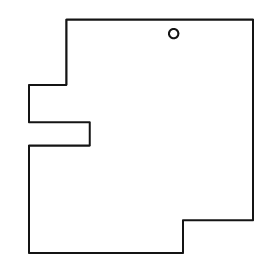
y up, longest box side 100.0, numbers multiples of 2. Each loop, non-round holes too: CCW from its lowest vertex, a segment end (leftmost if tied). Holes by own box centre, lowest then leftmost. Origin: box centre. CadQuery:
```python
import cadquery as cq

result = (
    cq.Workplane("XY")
    .moveTo(-48.0, -50.0)
    .lineTo(18.0, -50.0)
    .lineTo(18.0, -36.0)
    .lineTo(48.0, -36.0)
    .lineTo(48.0, 50.0)
    .lineTo(-32.0, 50.0)
    .lineTo(-32.0, 22.0)
    .lineTo(-48.0, 22.0)
    .lineTo(-48.0, 6.0)
    .lineTo(-22.0, 6.0)
    .lineTo(-22.0, -4.0)
    .lineTo(-48.0, -4.0)
    .close()
    .moveTo(14.0, 44.0)
    .circle(2.0)
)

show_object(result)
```